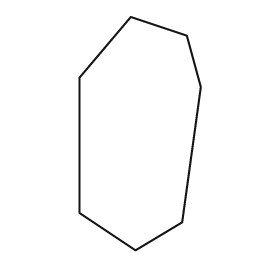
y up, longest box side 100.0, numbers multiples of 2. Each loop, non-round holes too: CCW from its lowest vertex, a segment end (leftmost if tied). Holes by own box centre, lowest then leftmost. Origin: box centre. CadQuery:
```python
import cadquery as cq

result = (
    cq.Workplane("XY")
    .moveTo(-2.0, -50.0)
    .lineTo(18.0, -38.0)
    .lineTo(26.0, 20.0)
    .lineTo(20.0, 42.0)
    .lineTo(-4.0, 50.0)
    .lineTo(-26.0, 24.0)
    .lineTo(-26.0, -34.0)
    .close()
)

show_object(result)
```